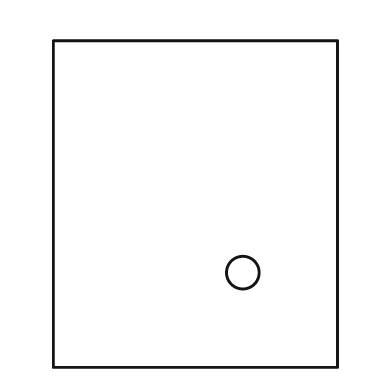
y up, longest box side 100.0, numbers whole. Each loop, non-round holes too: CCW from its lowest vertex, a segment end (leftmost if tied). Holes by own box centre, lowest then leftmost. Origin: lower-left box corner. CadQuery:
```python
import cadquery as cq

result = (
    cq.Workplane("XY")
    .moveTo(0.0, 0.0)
    .lineTo(87.0, 0.0)
    .lineTo(87.0, 100.0)
    .lineTo(0.0, 100.0)
    .close()
    .moveTo(58.0, 29.0)
    .circle(5.0)
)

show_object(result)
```